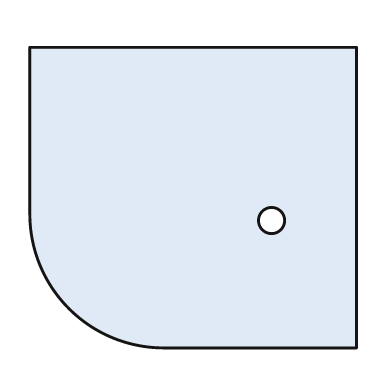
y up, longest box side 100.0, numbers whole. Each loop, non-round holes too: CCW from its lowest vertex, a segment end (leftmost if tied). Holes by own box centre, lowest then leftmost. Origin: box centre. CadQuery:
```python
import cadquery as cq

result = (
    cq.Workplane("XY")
    .moveTo(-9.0, -46.0)
    .lineTo(50.0, -46.0)
    .lineTo(50.0, 46.0)
    .lineTo(-50.0, 46.0)
    .lineTo(-50.0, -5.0)
    .threePointArc((-38.0, -34.0), (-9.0, -46.0))
    .close()
    .moveTo(24.0, -7.0)
    .circle(4.0)
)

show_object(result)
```